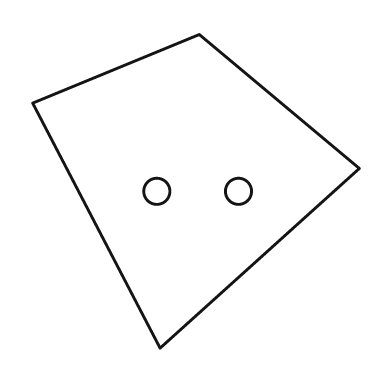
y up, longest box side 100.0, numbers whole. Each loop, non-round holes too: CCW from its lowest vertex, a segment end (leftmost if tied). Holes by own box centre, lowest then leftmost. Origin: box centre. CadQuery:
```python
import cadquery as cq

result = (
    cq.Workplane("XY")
    .moveTo(-11.0, -48.0)
    .lineTo(50.0, 7.0)
    .lineTo(1.0, 48.0)
    .lineTo(-50.0, 27.0)
    .close()
    .moveTo(-12.0, 0.0)
    .circle(4.0)
    .moveTo(13.0, 0.0)
    .circle(4.0)
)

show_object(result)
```